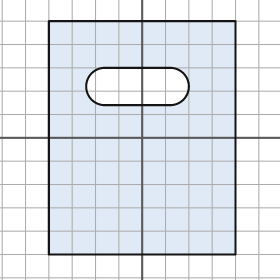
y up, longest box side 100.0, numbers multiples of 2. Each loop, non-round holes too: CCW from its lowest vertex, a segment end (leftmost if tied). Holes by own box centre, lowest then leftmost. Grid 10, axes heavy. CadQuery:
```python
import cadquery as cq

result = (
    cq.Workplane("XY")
    .moveTo(-40.0, -50.0)
    .lineTo(40.0, -50.0)
    .lineTo(40.0, 50.0)
    .lineTo(-40.0, 50.0)
    .close()
    .moveTo(-16.0, 14.0)
    .lineTo(12.0, 14.0)
    .threePointArc((20.0, 22.0), (12.0, 30.0))
    .lineTo(-16.0, 30.0)
    .threePointArc((-24.0, 22.0), (-16.0, 14.0))
    .close()
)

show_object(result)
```